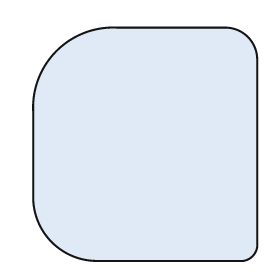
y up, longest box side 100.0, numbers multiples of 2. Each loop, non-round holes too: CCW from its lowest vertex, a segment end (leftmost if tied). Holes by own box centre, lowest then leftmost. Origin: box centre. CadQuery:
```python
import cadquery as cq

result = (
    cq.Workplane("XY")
    .moveTo(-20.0, -50.0)
    .lineTo(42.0, -50.0)
    .threePointArc((46.0, -48.0), (48.0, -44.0))
    .lineTo(48.0, 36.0)
    .threePointArc((44.0, 46.0), (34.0, 50.0))
    .lineTo(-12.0, 50.0)
    .threePointArc((-38.0, 40.0), (-48.0, 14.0))
    .lineTo(-48.0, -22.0)
    .threePointArc((-40.0, -42.0), (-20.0, -50.0))
    .close()
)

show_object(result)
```